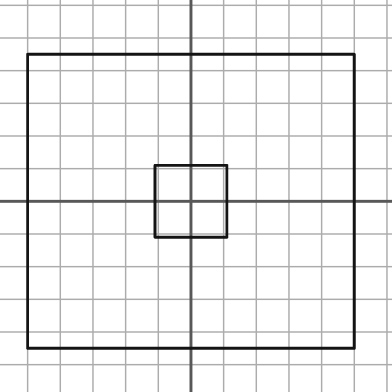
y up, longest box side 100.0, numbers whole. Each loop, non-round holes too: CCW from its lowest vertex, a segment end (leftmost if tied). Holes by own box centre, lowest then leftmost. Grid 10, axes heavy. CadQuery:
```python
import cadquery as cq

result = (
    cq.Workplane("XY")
    .moveTo(-50.0, -45.0)
    .lineTo(50.0, -45.0)
    .lineTo(50.0, 45.0)
    .lineTo(-50.0, 45.0)
    .close()
    .moveTo(-11.0, -11.0)
    .lineTo(11.0, -11.0)
    .lineTo(11.0, 11.0)
    .lineTo(-11.0, 11.0)
    .close()
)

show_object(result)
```